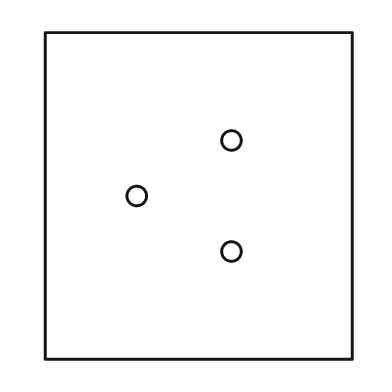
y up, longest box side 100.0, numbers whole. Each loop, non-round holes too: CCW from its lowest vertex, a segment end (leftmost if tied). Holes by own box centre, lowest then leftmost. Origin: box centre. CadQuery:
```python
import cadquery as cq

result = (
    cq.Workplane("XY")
    .moveTo(-47.0, -50.0)
    .lineTo(47.0, -50.0)
    .lineTo(47.0, 50.0)
    .lineTo(-47.0, 50.0)
    .close()
    .moveTo(10.0, -17.0)
    .circle(3.0)
    .moveTo(-19.0, 0.0)
    .circle(3.0)
    .moveTo(10.0, 17.0)
    .circle(3.0)
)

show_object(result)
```